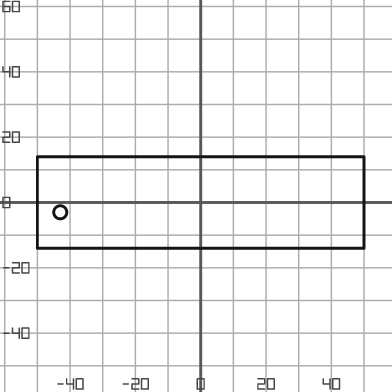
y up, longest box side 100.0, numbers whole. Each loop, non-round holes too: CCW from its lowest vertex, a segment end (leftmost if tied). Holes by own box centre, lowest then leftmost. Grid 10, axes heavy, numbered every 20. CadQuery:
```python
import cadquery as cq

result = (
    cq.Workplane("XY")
    .moveTo(-50.0, -14.0)
    .lineTo(50.0, -14.0)
    .lineTo(50.0, 14.0)
    .lineTo(-50.0, 14.0)
    .close()
    .moveTo(-43.0, -3.0)
    .circle(2.0)
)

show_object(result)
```